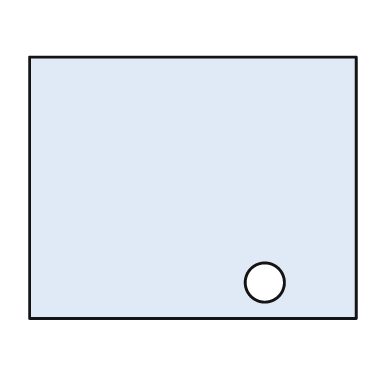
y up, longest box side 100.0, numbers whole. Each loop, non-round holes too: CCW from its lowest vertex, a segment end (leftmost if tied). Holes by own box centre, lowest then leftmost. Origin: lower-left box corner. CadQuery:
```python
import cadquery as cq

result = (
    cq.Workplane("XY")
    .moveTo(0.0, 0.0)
    .lineTo(100.0, 0.0)
    .lineTo(100.0, 80.0)
    .lineTo(0.0, 80.0)
    .close()
    .moveTo(72.0, 11.0)
    .circle(6.0)
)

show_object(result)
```